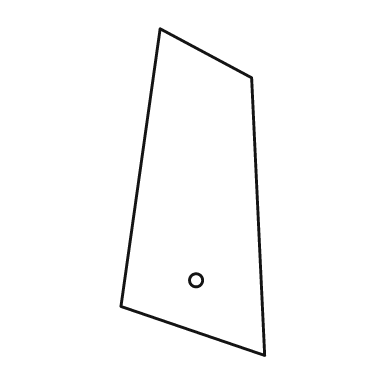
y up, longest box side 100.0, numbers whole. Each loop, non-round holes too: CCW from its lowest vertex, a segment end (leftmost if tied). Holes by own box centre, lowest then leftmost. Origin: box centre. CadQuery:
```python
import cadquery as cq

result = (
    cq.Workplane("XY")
    .moveTo(22.0, -50.0)
    .lineTo(18.0, 35.0)
    .lineTo(-10.0, 50.0)
    .lineTo(-22.0, -35.0)
    .close()
    .moveTo(1.0, -27.0)
    .circle(2.0)
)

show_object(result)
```